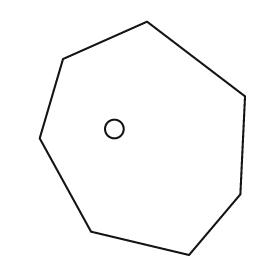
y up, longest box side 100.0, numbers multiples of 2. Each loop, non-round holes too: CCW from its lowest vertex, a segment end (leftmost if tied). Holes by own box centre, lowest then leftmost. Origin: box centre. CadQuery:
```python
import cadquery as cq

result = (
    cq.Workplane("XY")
    .moveTo(20.0, -50.0)
    .lineTo(42.0, -24.0)
    .lineTo(44.0, 18.0)
    .lineTo(2.0, 50.0)
    .lineTo(-34.0, 34.0)
    .lineTo(-44.0, 0.0)
    .lineTo(-22.0, -40.0)
    .close()
    .moveTo(-12.0, 4.0)
    .circle(4.0)
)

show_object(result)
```